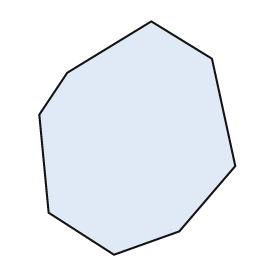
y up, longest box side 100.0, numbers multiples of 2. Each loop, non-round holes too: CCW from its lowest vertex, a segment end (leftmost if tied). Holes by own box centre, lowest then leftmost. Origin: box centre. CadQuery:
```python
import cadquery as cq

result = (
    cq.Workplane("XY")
    .moveTo(-10.0, -50.0)
    .lineTo(18.0, -40.0)
    .lineTo(42.0, -12.0)
    .lineTo(32.0, 34.0)
    .lineTo(6.0, 50.0)
    .lineTo(-30.0, 28.0)
    .lineTo(-42.0, 10.0)
    .lineTo(-38.0, -32.0)
    .close()
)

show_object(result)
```